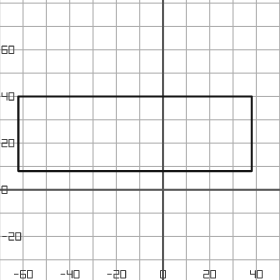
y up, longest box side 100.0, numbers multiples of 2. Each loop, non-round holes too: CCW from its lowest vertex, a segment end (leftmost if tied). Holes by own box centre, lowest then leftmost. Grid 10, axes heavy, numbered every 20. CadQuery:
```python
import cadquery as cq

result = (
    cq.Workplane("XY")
    .moveTo(-62.0, 8.0)
    .lineTo(38.0, 8.0)
    .lineTo(38.0, 40.0)
    .lineTo(-62.0, 40.0)
    .close()
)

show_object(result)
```